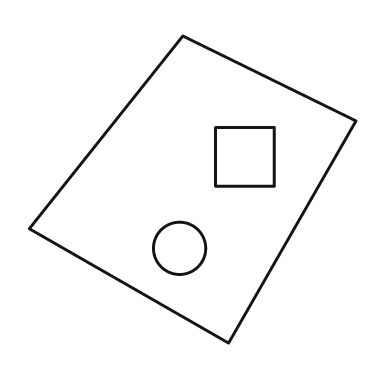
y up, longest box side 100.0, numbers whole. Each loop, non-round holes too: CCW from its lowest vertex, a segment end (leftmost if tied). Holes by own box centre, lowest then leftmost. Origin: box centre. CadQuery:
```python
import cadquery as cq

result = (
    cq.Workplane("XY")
    .moveTo(11.0, -47.0)
    .lineTo(50.0, 21.0)
    .lineTo(-3.0, 47.0)
    .lineTo(-50.0, -12.0)
    .close()
    .moveTo(-4.0, -18.0)
    .circle(8.0)
    .moveTo(7.0, 1.0)
    .lineTo(25.0, 1.0)
    .lineTo(25.0, 19.0)
    .lineTo(7.0, 19.0)
    .close()
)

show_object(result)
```